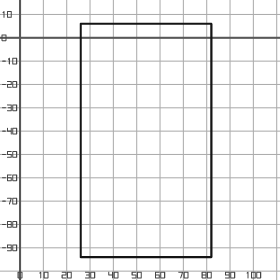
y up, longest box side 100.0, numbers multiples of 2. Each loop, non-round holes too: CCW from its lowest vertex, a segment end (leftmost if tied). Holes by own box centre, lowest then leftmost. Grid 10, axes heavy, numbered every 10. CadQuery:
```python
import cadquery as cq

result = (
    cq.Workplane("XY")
    .moveTo(26.0, -94.0)
    .lineTo(82.0, -94.0)
    .lineTo(82.0, 6.0)
    .lineTo(26.0, 6.0)
    .close()
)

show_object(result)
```